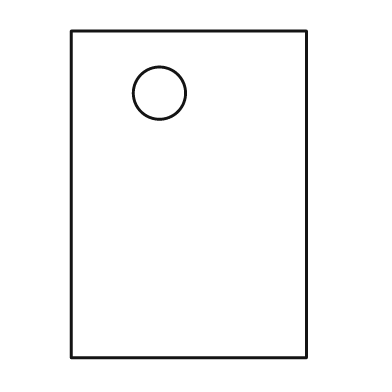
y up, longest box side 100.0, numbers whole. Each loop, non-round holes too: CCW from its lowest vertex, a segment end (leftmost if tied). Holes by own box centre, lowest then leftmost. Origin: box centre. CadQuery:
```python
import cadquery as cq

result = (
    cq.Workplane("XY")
    .moveTo(-36.0, -50.0)
    .lineTo(36.0, -50.0)
    .lineTo(36.0, 50.0)
    .lineTo(-36.0, 50.0)
    .close()
    .moveTo(-9.0, 31.0)
    .circle(8.0)
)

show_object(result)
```